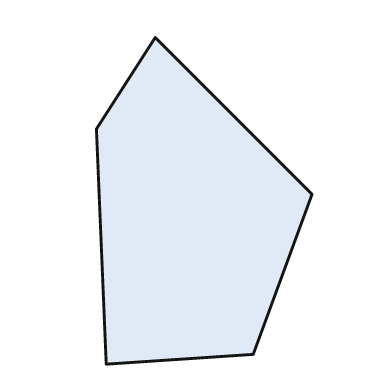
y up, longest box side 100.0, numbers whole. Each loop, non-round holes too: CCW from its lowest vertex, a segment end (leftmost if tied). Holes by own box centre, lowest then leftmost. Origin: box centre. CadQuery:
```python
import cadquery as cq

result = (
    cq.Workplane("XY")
    .moveTo(-30.0, -50.0)
    .lineTo(15.0, -47.0)
    .lineTo(33.0, 2.0)
    .lineTo(-15.0, 50.0)
    .lineTo(-33.0, 22.0)
    .close()
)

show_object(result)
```